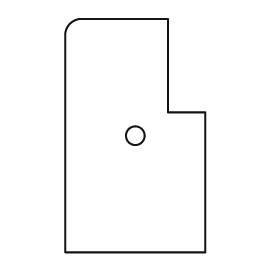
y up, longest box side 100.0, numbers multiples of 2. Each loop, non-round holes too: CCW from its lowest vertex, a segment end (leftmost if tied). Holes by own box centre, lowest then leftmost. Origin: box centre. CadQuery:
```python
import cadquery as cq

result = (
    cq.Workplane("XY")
    .moveTo(-30.0, -50.0)
    .lineTo(30.0, -50.0)
    .lineTo(30.0, 10.0)
    .lineTo(14.0, 10.0)
    .lineTo(14.0, 50.0)
    .lineTo(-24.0, 50.0)
    .threePointArc((-28.0, 48.0), (-30.0, 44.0))
    .close()
    .moveTo(0.0, 0.0)
    .circle(4.0)
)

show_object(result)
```